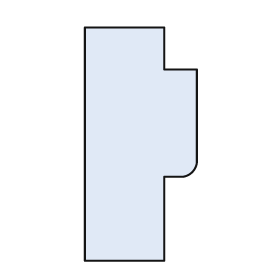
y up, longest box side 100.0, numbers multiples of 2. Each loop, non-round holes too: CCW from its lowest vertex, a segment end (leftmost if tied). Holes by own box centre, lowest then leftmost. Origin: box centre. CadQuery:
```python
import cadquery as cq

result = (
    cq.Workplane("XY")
    .moveTo(-24.0, -50.0)
    .lineTo(10.0, -50.0)
    .lineTo(10.0, -14.0)
    .lineTo(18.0, -14.0)
    .threePointArc((22.0, -12.0), (24.0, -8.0))
    .lineTo(24.0, 32.0)
    .lineTo(10.0, 32.0)
    .lineTo(10.0, 50.0)
    .lineTo(-24.0, 50.0)
    .close()
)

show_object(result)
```